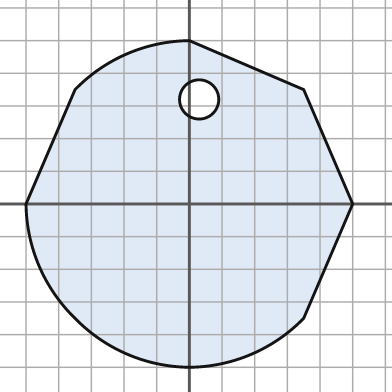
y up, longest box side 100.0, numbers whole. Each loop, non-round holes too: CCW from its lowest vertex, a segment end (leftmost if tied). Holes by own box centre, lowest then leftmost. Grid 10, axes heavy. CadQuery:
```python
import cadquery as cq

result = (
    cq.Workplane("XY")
    .moveTo(0.0, -50.0)
    .threePointArc((19.0, -46.0), (35.0, -35.0))
    .lineTo(50.0, 0.0)
    .lineTo(35.0, 35.0)
    .lineTo(0.0, 50.0)
    .threePointArc((-19.0, 46.0), (-35.0, 35.0))
    .lineTo(-50.0, 0.0)
    .threePointArc((-46.0, -19.0), (-35.0, -35.0))
    .threePointArc((-19.0, -46.0), (0.0, -50.0))
    .close()
    .moveTo(3.0, 32.0)
    .circle(6.0)
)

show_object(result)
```